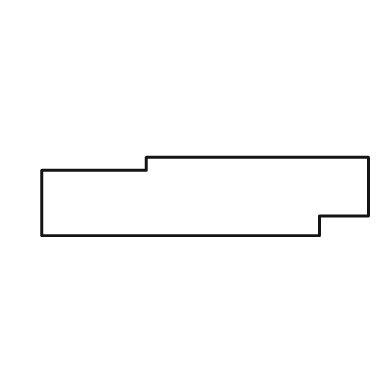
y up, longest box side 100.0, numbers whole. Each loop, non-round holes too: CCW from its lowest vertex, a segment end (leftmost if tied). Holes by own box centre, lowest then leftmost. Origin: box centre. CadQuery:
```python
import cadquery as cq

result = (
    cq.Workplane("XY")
    .moveTo(-50.0, -12.0)
    .lineTo(35.0, -12.0)
    .lineTo(35.0, -6.0)
    .lineTo(50.0, -6.0)
    .lineTo(50.0, 12.0)
    .lineTo(-18.0, 12.0)
    .lineTo(-18.0, 8.0)
    .lineTo(-50.0, 8.0)
    .close()
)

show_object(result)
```